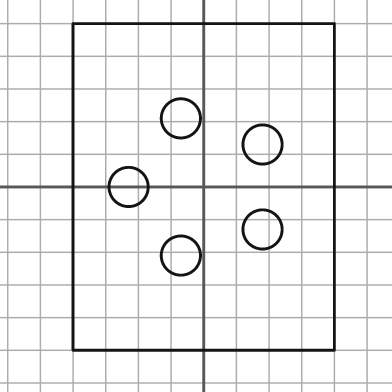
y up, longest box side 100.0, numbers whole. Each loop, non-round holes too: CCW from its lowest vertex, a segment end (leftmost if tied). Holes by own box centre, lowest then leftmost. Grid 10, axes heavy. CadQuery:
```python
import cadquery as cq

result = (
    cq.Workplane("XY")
    .moveTo(-40.0, -50.0)
    .lineTo(40.0, -50.0)
    .lineTo(40.0, 50.0)
    .lineTo(-40.0, 50.0)
    .close()
    .moveTo(-7.0, -21.0)
    .circle(6.0)
    .moveTo(18.0, -13.0)
    .circle(6.0)
    .moveTo(-23.0, 0.0)
    .circle(6.0)
    .moveTo(18.0, 13.0)
    .circle(6.0)
    .moveTo(-7.0, 21.0)
    .circle(6.0)
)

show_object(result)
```